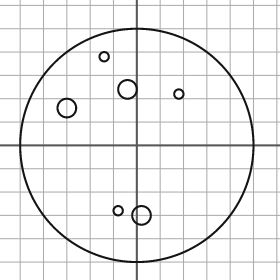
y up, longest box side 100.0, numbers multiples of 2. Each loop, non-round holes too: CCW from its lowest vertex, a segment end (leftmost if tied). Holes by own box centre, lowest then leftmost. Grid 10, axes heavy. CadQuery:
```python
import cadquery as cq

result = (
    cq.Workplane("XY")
    .moveTo(0.0, 0.0)
    .circle(50.0)
    .moveTo(2.0, -30.0)
    .circle(4.0)
    .moveTo(-8.0, -28.0)
    .circle(2.0)
    .moveTo(-30.0, 16.0)
    .circle(4.0)
    .moveTo(18.0, 22.0)
    .circle(2.0)
    .moveTo(-4.0, 24.0)
    .circle(4.0)
    .moveTo(-14.0, 38.0)
    .circle(2.0)
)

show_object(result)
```